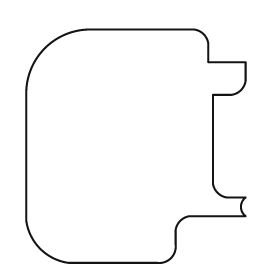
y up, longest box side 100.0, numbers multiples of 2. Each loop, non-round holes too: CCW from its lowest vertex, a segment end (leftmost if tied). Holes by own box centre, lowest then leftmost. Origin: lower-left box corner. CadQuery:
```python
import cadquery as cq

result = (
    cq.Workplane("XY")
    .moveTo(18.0, 0.0)
    .lineTo(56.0, 0.0)
    .threePointArc((62.0, 2.0), (64.0, 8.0))
    .lineTo(64.0, 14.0)
    .threePointArc((66.0, 18.0), (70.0, 20.0))
    .lineTo(94.0, 20.0)
    .threePointArc((92.0, 24.0), (94.0, 28.0))
    .lineTo(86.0, 28.0)
    .threePointArc((82.0, 30.0), (80.0, 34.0))
    .lineTo(80.0, 72.0)
    .lineTo(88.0, 72.0)
    .threePointArc((92.0, 74.0), (94.0, 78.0))
    .lineTo(94.0, 86.0)
    .lineTo(78.0, 86.0)
    .lineTo(78.0, 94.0)
    .threePointArc((76.0, 98.0), (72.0, 100.0))
    .lineTo(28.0, 100.0)
    .threePointArc((8.0, 92.0), (0.0, 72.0))
    .lineTo(0.0, 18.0)
    .threePointArc((6.0, 6.0), (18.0, 0.0))
    .close()
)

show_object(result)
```